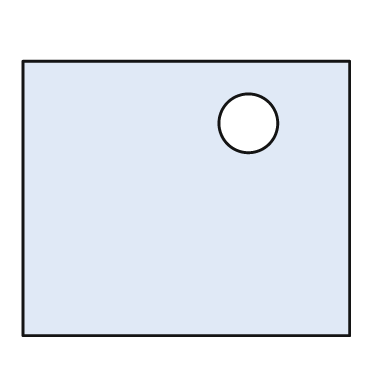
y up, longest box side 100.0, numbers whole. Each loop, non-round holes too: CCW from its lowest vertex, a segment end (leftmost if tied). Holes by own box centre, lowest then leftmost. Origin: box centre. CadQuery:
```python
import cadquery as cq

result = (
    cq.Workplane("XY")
    .moveTo(-50.0, -42.0)
    .lineTo(50.0, -42.0)
    .lineTo(50.0, 42.0)
    .lineTo(-50.0, 42.0)
    .close()
    .moveTo(19.0, 23.0)
    .circle(9.0)
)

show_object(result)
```